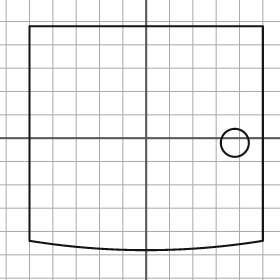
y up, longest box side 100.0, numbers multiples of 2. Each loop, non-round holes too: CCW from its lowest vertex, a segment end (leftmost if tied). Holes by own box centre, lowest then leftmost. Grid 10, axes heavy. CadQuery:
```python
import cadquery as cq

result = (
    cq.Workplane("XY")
    .moveTo(-50.0, -44.0)
    .threePointArc((0.0, -48.0), (50.0, -44.0))
    .lineTo(50.0, 48.0)
    .lineTo(-50.0, 48.0)
    .close()
    .moveTo(38.0, -2.0)
    .circle(6.0)
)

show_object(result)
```